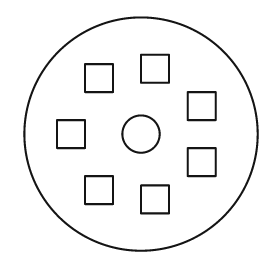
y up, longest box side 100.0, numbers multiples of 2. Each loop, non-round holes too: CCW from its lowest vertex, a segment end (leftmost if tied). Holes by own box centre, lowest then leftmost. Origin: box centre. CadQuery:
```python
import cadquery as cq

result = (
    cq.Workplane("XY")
    .moveTo(0.0, 0.0)
    .circle(50.0)
    .moveTo(0.0, -34.0)
    .lineTo(12.0, -34.0)
    .lineTo(12.0, -22.0)
    .lineTo(0.0, -22.0)
    .close()
    .moveTo(-24.0, -30.0)
    .lineTo(-12.0, -30.0)
    .lineTo(-12.0, -18.0)
    .lineTo(-24.0, -18.0)
    .close()
    .moveTo(20.0, -18.0)
    .lineTo(32.0, -18.0)
    .lineTo(32.0, -6.0)
    .lineTo(20.0, -6.0)
    .close()
    .moveTo(-36.0, -6.0)
    .lineTo(-24.0, -6.0)
    .lineTo(-24.0, 6.0)
    .lineTo(-36.0, 6.0)
    .close()
    .moveTo(0.0, 0.0)
    .circle(8.0)
    .moveTo(20.0, 6.0)
    .lineTo(32.0, 6.0)
    .lineTo(32.0, 18.0)
    .lineTo(20.0, 18.0)
    .close()
    .moveTo(-24.0, 18.0)
    .lineTo(-12.0, 18.0)
    .lineTo(-12.0, 30.0)
    .lineTo(-24.0, 30.0)
    .close()
    .moveTo(0.0, 22.0)
    .lineTo(12.0, 22.0)
    .lineTo(12.0, 34.0)
    .lineTo(0.0, 34.0)
    .close()
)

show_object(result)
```